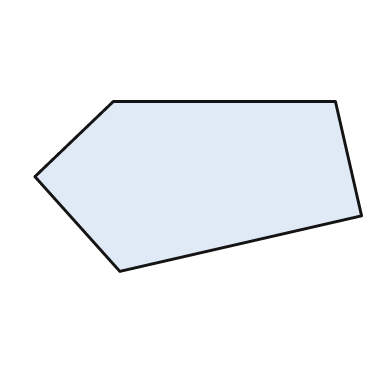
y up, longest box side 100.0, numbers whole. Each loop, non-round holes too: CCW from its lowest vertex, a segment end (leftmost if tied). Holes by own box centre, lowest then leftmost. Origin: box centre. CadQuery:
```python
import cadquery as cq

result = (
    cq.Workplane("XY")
    .moveTo(-24.0, -26.0)
    .lineTo(50.0, -9.0)
    .lineTo(42.0, 26.0)
    .lineTo(-26.0, 26.0)
    .lineTo(-50.0, 3.0)
    .close()
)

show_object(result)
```